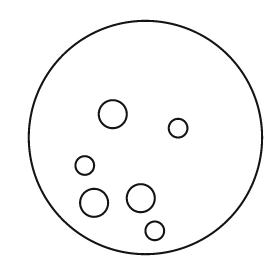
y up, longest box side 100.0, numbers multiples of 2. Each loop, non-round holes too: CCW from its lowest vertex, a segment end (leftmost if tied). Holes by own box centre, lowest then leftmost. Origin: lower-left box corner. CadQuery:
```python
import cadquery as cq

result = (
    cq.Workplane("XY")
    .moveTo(50.0, 50.0)
    .circle(50.0)
    .moveTo(54.0, 10.0)
    .circle(4.0)
    .moveTo(28.0, 22.0)
    .circle(6.0)
    .moveTo(48.0, 24.0)
    .circle(6.0)
    .moveTo(24.0, 38.0)
    .circle(4.0)
    .moveTo(64.0, 54.0)
    .circle(4.0)
    .moveTo(36.0, 60.0)
    .circle(6.0)
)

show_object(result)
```